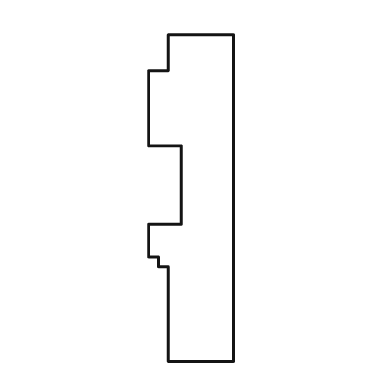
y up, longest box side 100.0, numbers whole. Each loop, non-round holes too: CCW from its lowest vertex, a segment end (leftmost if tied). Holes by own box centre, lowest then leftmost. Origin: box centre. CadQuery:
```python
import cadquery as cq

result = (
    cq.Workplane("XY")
    .moveTo(-7.0, -50.0)
    .lineTo(13.0, -50.0)
    .lineTo(13.0, 50.0)
    .lineTo(-7.0, 50.0)
    .lineTo(-7.0, 39.0)
    .lineTo(-13.0, 39.0)
    .lineTo(-13.0, 16.0)
    .lineTo(-3.0, 16.0)
    .lineTo(-3.0, -8.0)
    .lineTo(-13.0, -8.0)
    .lineTo(-13.0, -18.0)
    .lineTo(-10.0, -18.0)
    .lineTo(-10.0, -21.0)
    .lineTo(-7.0, -21.0)
    .close()
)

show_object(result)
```